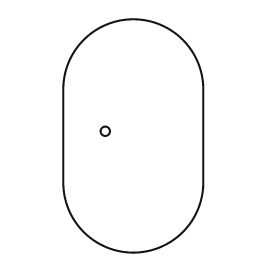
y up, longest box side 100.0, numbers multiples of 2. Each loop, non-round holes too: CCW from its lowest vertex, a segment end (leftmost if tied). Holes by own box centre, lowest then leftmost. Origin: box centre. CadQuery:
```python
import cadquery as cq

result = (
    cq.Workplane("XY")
    .moveTo(-30.0, -20.0)
    .threePointArc((0.0, -50.0), (30.0, -20.0))
    .lineTo(30.0, 20.0)
    .threePointArc((0.0, 50.0), (-30.0, 20.0))
    .close()
    .moveTo(-12.0, 2.0)
    .circle(2.0)
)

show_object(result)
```